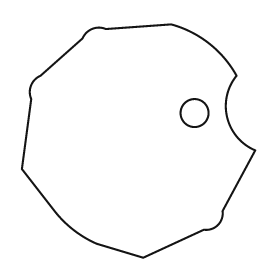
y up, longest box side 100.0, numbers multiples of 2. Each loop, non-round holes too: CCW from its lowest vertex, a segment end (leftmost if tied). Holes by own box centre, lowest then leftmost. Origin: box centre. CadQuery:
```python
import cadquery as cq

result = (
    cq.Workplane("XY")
    .moveTo(2.0, -50.0)
    .lineTo(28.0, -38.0)
    .threePointArc((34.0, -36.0), (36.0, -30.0))
    .lineTo(50.0, -4.0)
    .threePointArc((38.0, 10.0), (42.0, 28.0))
    .threePointArc((30.0, 42.0), (14.0, 50.0))
    .lineTo(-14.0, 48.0)
    .threePointArc((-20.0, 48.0), (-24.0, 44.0))
    .lineTo(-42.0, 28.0)
    .threePointArc((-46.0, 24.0), (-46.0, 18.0))
    .lineTo(-50.0, -12.0)
    .lineTo(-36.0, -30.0)
    .threePointArc((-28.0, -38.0), (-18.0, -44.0))
    .close()
    .moveTo(24.0, 12.0)
    .circle(6.0)
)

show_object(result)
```